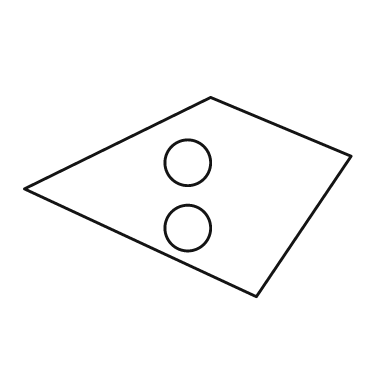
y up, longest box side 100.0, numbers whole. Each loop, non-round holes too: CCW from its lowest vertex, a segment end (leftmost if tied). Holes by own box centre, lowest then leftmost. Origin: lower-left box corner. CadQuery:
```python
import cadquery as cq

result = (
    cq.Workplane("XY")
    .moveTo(71.0, 0.0)
    .lineTo(100.0, 43.0)
    .lineTo(57.0, 61.0)
    .lineTo(0.0, 33.0)
    .close()
    .moveTo(50.0, 21.0)
    .circle(7.0)
    .moveTo(50.0, 41.0)
    .circle(7.0)
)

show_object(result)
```